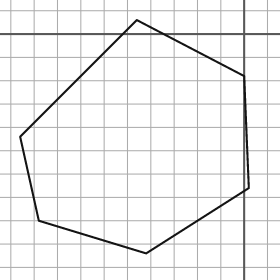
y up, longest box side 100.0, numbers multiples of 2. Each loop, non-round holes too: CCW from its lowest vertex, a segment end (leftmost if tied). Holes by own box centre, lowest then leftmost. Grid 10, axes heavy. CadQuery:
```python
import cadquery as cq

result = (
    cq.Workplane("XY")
    .moveTo(-42.0, -94.0)
    .lineTo(2.0, -66.0)
    .lineTo(0.0, -18.0)
    .lineTo(-46.0, 6.0)
    .lineTo(-96.0, -44.0)
    .lineTo(-88.0, -80.0)
    .close()
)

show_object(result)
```